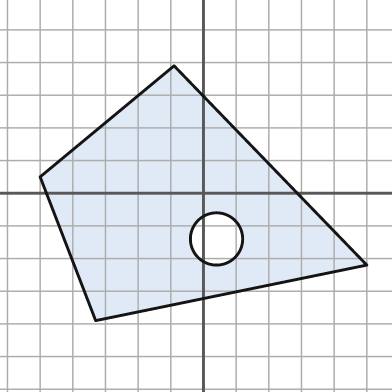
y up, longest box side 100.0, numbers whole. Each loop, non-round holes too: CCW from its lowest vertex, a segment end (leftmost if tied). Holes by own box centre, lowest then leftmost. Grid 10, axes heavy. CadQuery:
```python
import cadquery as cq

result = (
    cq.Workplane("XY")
    .moveTo(-33.0, -39.0)
    .lineTo(50.0, -22.0)
    .lineTo(-9.0, 39.0)
    .lineTo(-50.0, 5.0)
    .close()
    .moveTo(4.0, -14.0)
    .circle(8.0)
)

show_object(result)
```